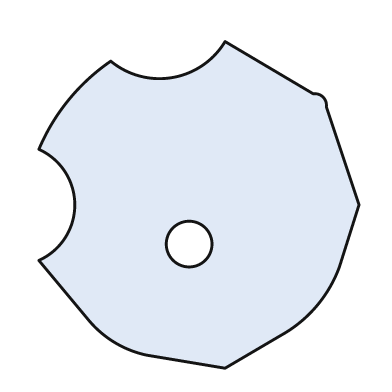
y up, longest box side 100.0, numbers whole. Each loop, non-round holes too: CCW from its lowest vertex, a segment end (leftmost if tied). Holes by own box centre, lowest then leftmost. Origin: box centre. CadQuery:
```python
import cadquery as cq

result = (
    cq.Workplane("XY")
    .moveTo(8.0, -50.0)
    .lineTo(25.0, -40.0)
    .threePointArc((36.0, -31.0), (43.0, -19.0))
    .lineTo(49.0, 0.0)
    .lineTo(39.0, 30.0)
    .threePointArc((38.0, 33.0), (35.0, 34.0))
    .lineTo(8.0, 50.0)
    .threePointArc((-8.0, 39.0), (-27.0, 44.0))
    .threePointArc((-40.0, 32.0), (-49.0, 17.0))
    .threePointArc((-38.0, 0.0), (-49.0, -17.0))
    .lineTo(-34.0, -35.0)
    .threePointArc((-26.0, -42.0), (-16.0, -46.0))
    .close()
    .moveTo(-3.0, -12.0)
    .circle(7.0)
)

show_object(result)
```